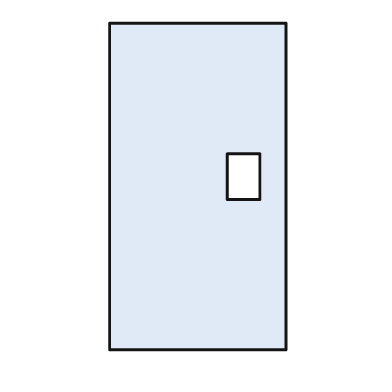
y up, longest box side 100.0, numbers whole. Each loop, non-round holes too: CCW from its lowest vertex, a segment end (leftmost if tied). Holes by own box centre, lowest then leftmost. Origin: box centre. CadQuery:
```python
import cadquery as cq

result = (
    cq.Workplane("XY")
    .moveTo(-27.0, -50.0)
    .lineTo(27.0, -50.0)
    .lineTo(27.0, 50.0)
    .lineTo(-27.0, 50.0)
    .close()
    .moveTo(9.0, -4.0)
    .lineTo(19.0, -4.0)
    .lineTo(19.0, 10.0)
    .lineTo(9.0, 10.0)
    .close()
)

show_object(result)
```